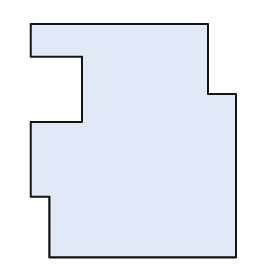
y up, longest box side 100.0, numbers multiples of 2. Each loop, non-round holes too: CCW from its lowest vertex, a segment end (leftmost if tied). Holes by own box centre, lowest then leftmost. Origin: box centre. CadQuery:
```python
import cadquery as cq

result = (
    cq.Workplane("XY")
    .moveTo(-36.0, -50.0)
    .lineTo(44.0, -50.0)
    .lineTo(44.0, 20.0)
    .lineTo(32.0, 20.0)
    .lineTo(32.0, 50.0)
    .lineTo(-44.0, 50.0)
    .lineTo(-44.0, 36.0)
    .lineTo(-22.0, 36.0)
    .lineTo(-22.0, 8.0)
    .lineTo(-44.0, 8.0)
    .lineTo(-44.0, -24.0)
    .lineTo(-36.0, -24.0)
    .close()
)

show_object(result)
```